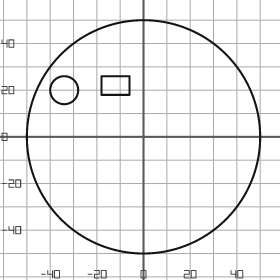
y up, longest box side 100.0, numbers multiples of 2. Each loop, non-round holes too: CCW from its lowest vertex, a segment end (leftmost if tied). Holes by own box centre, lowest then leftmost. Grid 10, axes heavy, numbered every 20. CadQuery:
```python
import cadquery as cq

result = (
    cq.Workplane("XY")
    .moveTo(0.0, 0.0)
    .circle(50.0)
    .moveTo(-34.0, 20.0)
    .circle(6.0)
    .moveTo(-18.0, 18.0)
    .lineTo(-6.0, 18.0)
    .lineTo(-6.0, 26.0)
    .lineTo(-18.0, 26.0)
    .close()
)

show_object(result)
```